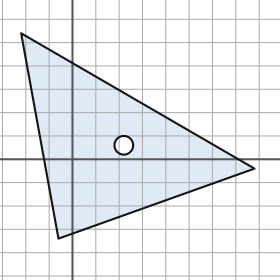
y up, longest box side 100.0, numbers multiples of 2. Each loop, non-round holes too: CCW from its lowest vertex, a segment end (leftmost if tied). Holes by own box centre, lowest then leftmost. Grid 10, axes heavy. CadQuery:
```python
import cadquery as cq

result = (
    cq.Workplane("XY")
    .moveTo(-6.0, -34.0)
    .lineTo(78.0, -4.0)
    .lineTo(-22.0, 54.0)
    .close()
    .moveTo(22.0, 6.0)
    .circle(4.0)
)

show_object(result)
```